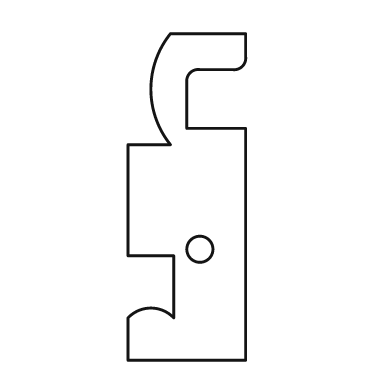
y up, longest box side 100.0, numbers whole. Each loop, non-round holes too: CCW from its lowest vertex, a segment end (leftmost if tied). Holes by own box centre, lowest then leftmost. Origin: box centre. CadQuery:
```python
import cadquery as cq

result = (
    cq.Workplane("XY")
    .moveTo(-18.0, -50.0)
    .lineTo(18.0, -50.0)
    .lineTo(18.0, 21.0)
    .lineTo(0.0, 21.0)
    .lineTo(0.0, 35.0)
    .threePointArc((1.0, 38.0), (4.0, 39.0))
    .lineTo(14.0, 39.0)
    .threePointArc((17.0, 40.0), (18.0, 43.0))
    .lineTo(18.0, 50.0)
    .lineTo(-5.0, 50.0)
    .threePointArc((-11.0, 33.0), (-5.0, 16.0))
    .lineTo(-18.0, 16.0)
    .lineTo(-18.0, -18.0)
    .lineTo(-4.0, -18.0)
    .lineTo(-4.0, -37.0)
    .threePointArc((-11.0, -34.0), (-18.0, -37.0))
    .close()
    .moveTo(4.0, -16.0)
    .circle(4.0)
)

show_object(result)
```